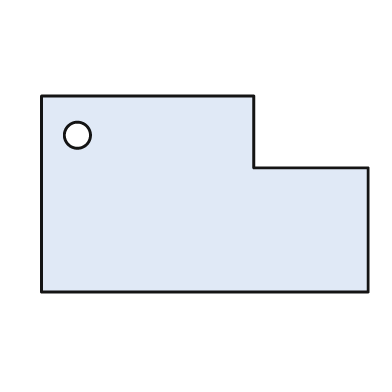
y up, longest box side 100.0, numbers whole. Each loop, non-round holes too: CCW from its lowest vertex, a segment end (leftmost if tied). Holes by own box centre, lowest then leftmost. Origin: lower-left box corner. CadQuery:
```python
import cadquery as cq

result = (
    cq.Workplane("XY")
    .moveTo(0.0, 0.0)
    .lineTo(100.0, 0.0)
    .lineTo(100.0, 38.0)
    .lineTo(65.0, 38.0)
    .lineTo(65.0, 60.0)
    .lineTo(0.0, 60.0)
    .close()
    .moveTo(11.0, 48.0)
    .circle(4.0)
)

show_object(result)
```